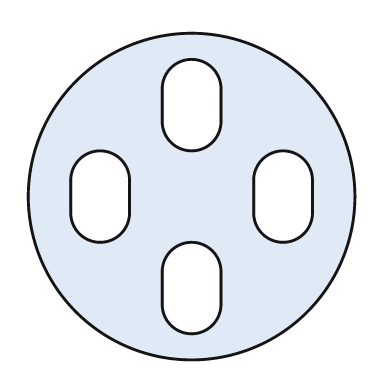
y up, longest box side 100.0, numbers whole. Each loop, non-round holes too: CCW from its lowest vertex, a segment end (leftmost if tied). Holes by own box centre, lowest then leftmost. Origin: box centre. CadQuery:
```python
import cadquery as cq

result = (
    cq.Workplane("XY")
    .moveTo(0.0, 0.0)
    .circle(50.0)
    .moveTo(-9.0, -33.0)
    .threePointArc((0.0, -42.0), (9.0, -33.0))
    .lineTo(9.0, -23.0)
    .threePointArc((0.0, -14.0), (-9.0, -23.0))
    .close()
    .moveTo(-37.0, -5.0)
    .threePointArc((-28.0, -14.0), (-19.0, -5.0))
    .lineTo(-19.0, 5.0)
    .threePointArc((-28.0, 14.0), (-37.0, 5.0))
    .close()
    .moveTo(19.0, -5.0)
    .threePointArc((28.0, -14.0), (37.0, -5.0))
    .lineTo(37.0, 5.0)
    .threePointArc((28.0, 14.0), (19.0, 5.0))
    .close()
    .moveTo(-9.0, 23.0)
    .threePointArc((0.0, 14.0), (9.0, 23.0))
    .lineTo(9.0, 33.0)
    .threePointArc((0.0, 42.0), (-9.0, 33.0))
    .close()
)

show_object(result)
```